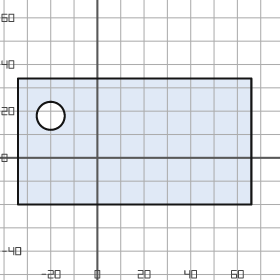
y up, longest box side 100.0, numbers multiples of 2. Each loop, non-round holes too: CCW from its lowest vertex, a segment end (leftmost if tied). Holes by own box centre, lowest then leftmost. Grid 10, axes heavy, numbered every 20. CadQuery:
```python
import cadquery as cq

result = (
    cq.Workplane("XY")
    .moveTo(-34.0, -20.0)
    .lineTo(66.0, -20.0)
    .lineTo(66.0, 34.0)
    .lineTo(-34.0, 34.0)
    .close()
    .moveTo(-20.0, 18.0)
    .circle(6.0)
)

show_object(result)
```